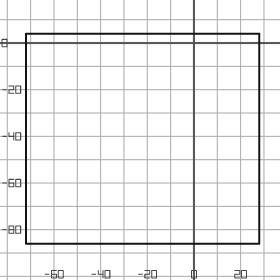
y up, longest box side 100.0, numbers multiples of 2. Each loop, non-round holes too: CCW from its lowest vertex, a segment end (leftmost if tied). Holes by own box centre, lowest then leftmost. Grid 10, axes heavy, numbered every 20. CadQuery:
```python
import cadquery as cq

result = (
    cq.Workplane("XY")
    .moveTo(-72.0, -86.0)
    .lineTo(28.0, -86.0)
    .lineTo(28.0, 4.0)
    .lineTo(-72.0, 4.0)
    .close()
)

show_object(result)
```